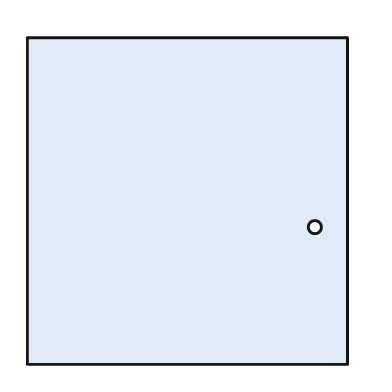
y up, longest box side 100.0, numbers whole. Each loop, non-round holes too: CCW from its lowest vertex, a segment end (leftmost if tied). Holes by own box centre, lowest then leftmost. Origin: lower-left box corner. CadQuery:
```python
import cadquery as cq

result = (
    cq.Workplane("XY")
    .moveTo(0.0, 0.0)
    .lineTo(98.0, 0.0)
    .lineTo(98.0, 100.0)
    .lineTo(0.0, 100.0)
    .close()
    .moveTo(88.0, 42.0)
    .circle(2.0)
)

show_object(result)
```